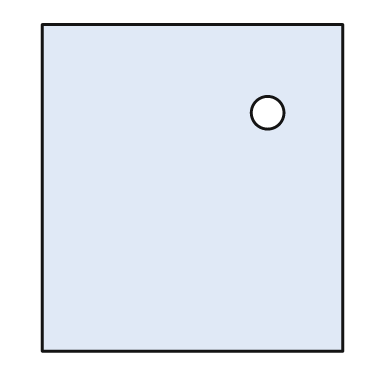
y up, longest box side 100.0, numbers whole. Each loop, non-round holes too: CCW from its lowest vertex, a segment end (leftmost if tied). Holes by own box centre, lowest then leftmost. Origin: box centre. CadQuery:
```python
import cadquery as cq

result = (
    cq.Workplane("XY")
    .moveTo(-46.0, -50.0)
    .lineTo(46.0, -50.0)
    .lineTo(46.0, 50.0)
    .lineTo(-46.0, 50.0)
    .close()
    .moveTo(23.0, 23.0)
    .circle(5.0)
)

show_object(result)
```